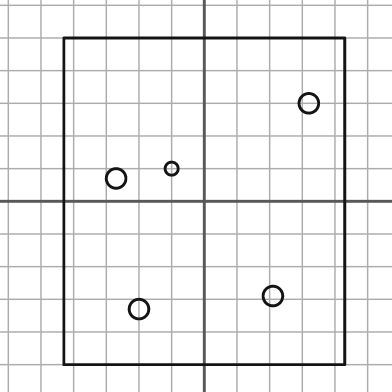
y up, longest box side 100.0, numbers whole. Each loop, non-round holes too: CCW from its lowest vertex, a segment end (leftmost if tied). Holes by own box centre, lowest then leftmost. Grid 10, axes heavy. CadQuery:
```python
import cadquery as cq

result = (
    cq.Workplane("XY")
    .moveTo(-43.0, -50.0)
    .lineTo(43.0, -50.0)
    .lineTo(43.0, 50.0)
    .lineTo(-43.0, 50.0)
    .close()
    .moveTo(-20.0, -33.0)
    .circle(3.0)
    .moveTo(21.0, -29.0)
    .circle(3.0)
    .moveTo(-27.0, 7.0)
    .circle(3.0)
    .moveTo(-10.0, 10.0)
    .circle(2.0)
    .moveTo(32.0, 30.0)
    .circle(3.0)
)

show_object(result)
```